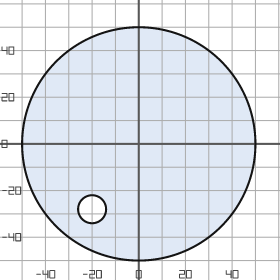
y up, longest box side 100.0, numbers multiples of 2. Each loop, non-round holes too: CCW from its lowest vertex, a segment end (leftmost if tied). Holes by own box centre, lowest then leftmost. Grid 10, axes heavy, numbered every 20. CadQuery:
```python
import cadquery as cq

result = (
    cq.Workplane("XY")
    .moveTo(0.0, 0.0)
    .circle(50.0)
    .moveTo(-20.0, -28.0)
    .circle(6.0)
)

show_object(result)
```